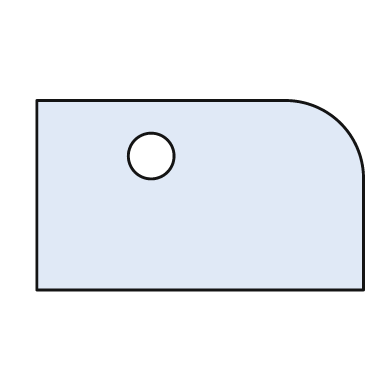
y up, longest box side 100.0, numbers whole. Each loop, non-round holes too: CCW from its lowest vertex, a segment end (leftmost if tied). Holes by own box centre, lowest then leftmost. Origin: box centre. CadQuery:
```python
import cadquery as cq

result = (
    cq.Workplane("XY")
    .moveTo(-50.0, -29.0)
    .lineTo(50.0, -29.0)
    .lineTo(50.0, 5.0)
    .threePointArc((43.0, 22.0), (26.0, 29.0))
    .lineTo(-50.0, 29.0)
    .close()
    .moveTo(-15.0, 12.0)
    .circle(7.0)
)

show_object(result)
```